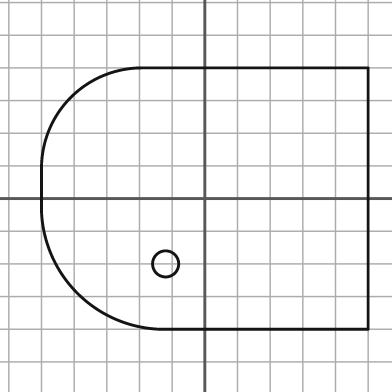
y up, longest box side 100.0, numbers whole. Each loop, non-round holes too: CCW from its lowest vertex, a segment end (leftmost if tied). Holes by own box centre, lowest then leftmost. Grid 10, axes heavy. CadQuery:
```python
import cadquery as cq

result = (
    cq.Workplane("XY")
    .moveTo(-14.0, -40.0)
    .lineTo(50.0, -40.0)
    .lineTo(50.0, 40.0)
    .lineTo(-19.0, 40.0)
    .threePointArc((-41.0, 31.0), (-50.0, 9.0))
    .lineTo(-50.0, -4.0)
    .threePointArc((-39.0, -29.0), (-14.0, -40.0))
    .close()
    .moveTo(-12.0, -20.0)
    .circle(4.0)
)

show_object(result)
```